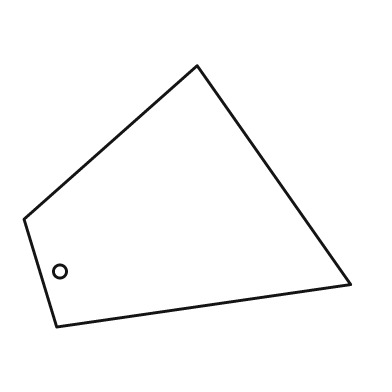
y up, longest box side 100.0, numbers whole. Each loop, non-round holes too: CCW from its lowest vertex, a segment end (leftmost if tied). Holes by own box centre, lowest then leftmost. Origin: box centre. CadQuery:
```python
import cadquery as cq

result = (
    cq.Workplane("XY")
    .moveTo(-40.0, -40.0)
    .lineTo(50.0, -27.0)
    .lineTo(3.0, 40.0)
    .lineTo(-50.0, -7.0)
    .close()
    .moveTo(-39.0, -23.0)
    .circle(2.0)
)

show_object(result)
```